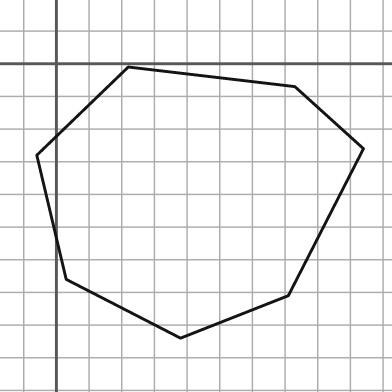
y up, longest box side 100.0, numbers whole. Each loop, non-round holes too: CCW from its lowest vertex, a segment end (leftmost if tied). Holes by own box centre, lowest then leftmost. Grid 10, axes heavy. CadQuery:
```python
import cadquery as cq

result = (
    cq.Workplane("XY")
    .moveTo(38.0, -84.0)
    .lineTo(71.0, -71.0)
    .lineTo(94.0, -26.0)
    .lineTo(73.0, -7.0)
    .lineTo(22.0, -1.0)
    .lineTo(-6.0, -28.0)
    .lineTo(3.0, -66.0)
    .close()
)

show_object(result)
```